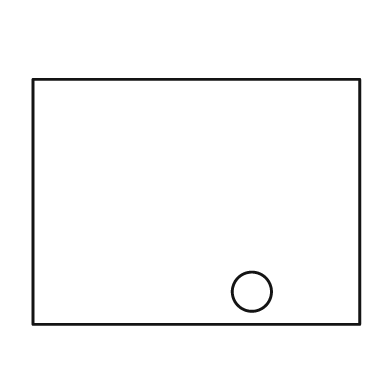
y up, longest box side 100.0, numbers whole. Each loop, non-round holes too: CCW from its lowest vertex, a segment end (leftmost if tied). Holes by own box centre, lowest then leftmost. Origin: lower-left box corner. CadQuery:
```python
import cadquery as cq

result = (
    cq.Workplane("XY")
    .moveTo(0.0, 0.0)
    .lineTo(100.0, 0.0)
    .lineTo(100.0, 75.0)
    .lineTo(0.0, 75.0)
    .close()
    .moveTo(67.0, 10.0)
    .circle(6.0)
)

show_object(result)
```